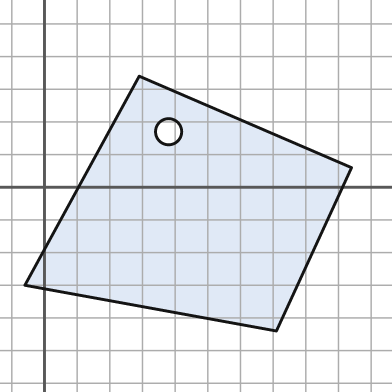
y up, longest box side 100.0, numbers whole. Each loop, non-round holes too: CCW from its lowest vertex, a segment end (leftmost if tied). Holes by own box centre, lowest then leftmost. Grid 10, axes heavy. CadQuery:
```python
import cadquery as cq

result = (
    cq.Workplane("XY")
    .moveTo(71.0, -44.0)
    .lineTo(94.0, 6.0)
    .lineTo(29.0, 34.0)
    .lineTo(-6.0, -30.0)
    .close()
    .moveTo(38.0, 17.0)
    .circle(4.0)
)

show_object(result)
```